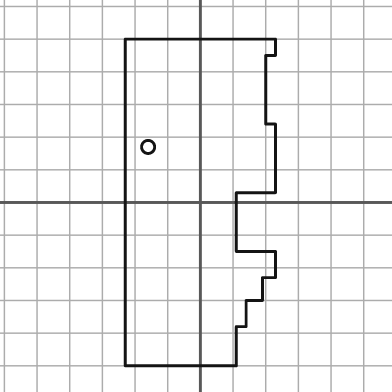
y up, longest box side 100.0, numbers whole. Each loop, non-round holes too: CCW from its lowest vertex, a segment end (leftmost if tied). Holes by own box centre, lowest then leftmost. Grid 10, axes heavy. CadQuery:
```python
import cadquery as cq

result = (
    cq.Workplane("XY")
    .moveTo(-23.0, -50.0)
    .lineTo(11.0, -50.0)
    .lineTo(11.0, -38.0)
    .lineTo(14.0, -38.0)
    .lineTo(14.0, -30.0)
    .lineTo(19.0, -30.0)
    .lineTo(19.0, -23.0)
    .lineTo(23.0, -23.0)
    .lineTo(23.0, -15.0)
    .lineTo(11.0, -15.0)
    .lineTo(11.0, 3.0)
    .lineTo(23.0, 3.0)
    .lineTo(23.0, 24.0)
    .lineTo(20.0, 24.0)
    .lineTo(20.0, 45.0)
    .lineTo(23.0, 45.0)
    .lineTo(23.0, 50.0)
    .lineTo(-23.0, 50.0)
    .close()
    .moveTo(-16.0, 17.0)
    .circle(2.0)
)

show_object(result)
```